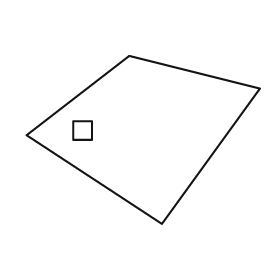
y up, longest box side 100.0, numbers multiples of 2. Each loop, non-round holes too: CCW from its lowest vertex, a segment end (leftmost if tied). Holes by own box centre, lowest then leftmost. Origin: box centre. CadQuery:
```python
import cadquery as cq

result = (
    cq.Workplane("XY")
    .moveTo(8.0, -36.0)
    .lineTo(50.0, 22.0)
    .lineTo(-6.0, 36.0)
    .lineTo(-50.0, 2.0)
    .close()
    .moveTo(-30.0, 0.0)
    .lineTo(-22.0, 0.0)
    .lineTo(-22.0, 8.0)
    .lineTo(-30.0, 8.0)
    .close()
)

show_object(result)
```